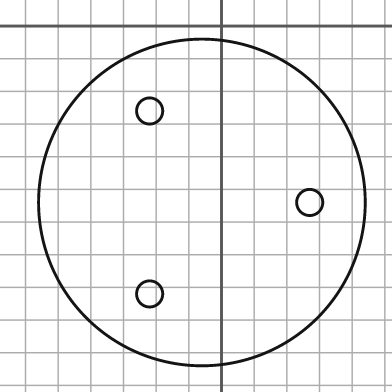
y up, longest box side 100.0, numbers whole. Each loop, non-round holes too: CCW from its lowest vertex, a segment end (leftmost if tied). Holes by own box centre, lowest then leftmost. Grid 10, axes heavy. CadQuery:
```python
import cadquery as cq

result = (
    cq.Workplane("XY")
    .moveTo(-6.0, -54.0)
    .circle(50.0)
    .moveTo(-22.0, -82.0)
    .circle(4.0)
    .moveTo(27.0, -54.0)
    .circle(4.0)
    .moveTo(-22.0, -26.0)
    .circle(4.0)
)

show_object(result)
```